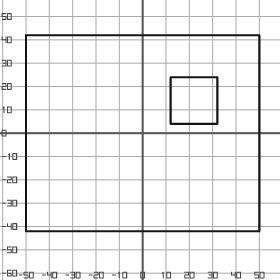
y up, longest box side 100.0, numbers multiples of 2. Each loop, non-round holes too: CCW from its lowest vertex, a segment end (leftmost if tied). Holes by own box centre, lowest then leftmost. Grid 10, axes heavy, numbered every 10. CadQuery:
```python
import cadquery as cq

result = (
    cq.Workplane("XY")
    .moveTo(-50.0, -42.0)
    .lineTo(50.0, -42.0)
    .lineTo(50.0, 42.0)
    .lineTo(-50.0, 42.0)
    .close()
    .moveTo(12.0, 4.0)
    .lineTo(32.0, 4.0)
    .lineTo(32.0, 24.0)
    .lineTo(12.0, 24.0)
    .close()
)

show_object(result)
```